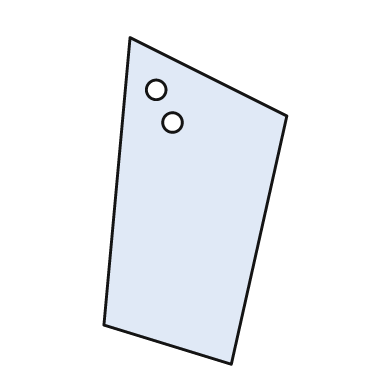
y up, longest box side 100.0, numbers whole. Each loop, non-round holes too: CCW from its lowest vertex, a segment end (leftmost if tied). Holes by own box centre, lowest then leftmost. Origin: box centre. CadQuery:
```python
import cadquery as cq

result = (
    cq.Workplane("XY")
    .moveTo(11.0, -50.0)
    .lineTo(28.0, 26.0)
    .lineTo(-20.0, 50.0)
    .lineTo(-28.0, -38.0)
    .close()
    .moveTo(-7.0, 24.0)
    .circle(3.0)
    .moveTo(-12.0, 34.0)
    .circle(3.0)
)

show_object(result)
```